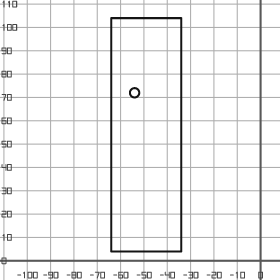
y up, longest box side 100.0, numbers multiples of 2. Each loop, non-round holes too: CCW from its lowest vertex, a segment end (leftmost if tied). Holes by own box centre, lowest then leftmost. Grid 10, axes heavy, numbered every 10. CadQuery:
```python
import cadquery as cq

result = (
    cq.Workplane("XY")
    .moveTo(-64.0, 4.0)
    .lineTo(-34.0, 4.0)
    .lineTo(-34.0, 104.0)
    .lineTo(-64.0, 104.0)
    .close()
    .moveTo(-54.0, 72.0)
    .circle(2.0)
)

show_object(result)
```